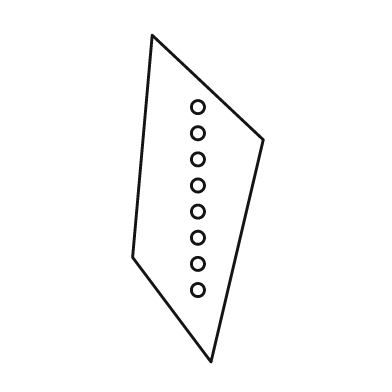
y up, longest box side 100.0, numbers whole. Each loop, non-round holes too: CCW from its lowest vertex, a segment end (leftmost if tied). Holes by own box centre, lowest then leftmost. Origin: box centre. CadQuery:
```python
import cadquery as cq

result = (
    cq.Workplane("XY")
    .moveTo(4.0, -50.0)
    .lineTo(20.0, 18.0)
    .lineTo(-14.0, 50.0)
    .lineTo(-20.0, -18.0)
    .close()
    .moveTo(0.0, -28.0)
    .circle(2.0)
    .moveTo(0.0, -20.0)
    .circle(2.0)
    .moveTo(0.0, -12.0)
    .circle(2.0)
    .moveTo(0.0, -4.0)
    .circle(2.0)
    .moveTo(0.0, 4.0)
    .circle(2.0)
    .moveTo(0.0, 12.0)
    .circle(2.0)
    .moveTo(0.0, 20.0)
    .circle(2.0)
    .moveTo(0.0, 28.0)
    .circle(2.0)
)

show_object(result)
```